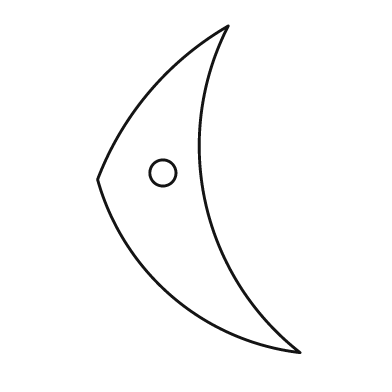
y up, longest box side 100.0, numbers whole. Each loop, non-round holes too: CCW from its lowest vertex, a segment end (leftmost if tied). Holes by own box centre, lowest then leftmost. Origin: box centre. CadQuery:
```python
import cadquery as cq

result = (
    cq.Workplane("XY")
    .moveTo(31.0, -50.0)
    .threePointArc((2.0, -4.0), (9.0, 50.0))
    .threePointArc((-15.0, 30.0), (-31.0, 3.0))
    .threePointArc((-8.0, -33.0), (31.0, -50.0))
    .close()
    .moveTo(-11.0, 5.0)
    .circle(4.0)
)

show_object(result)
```